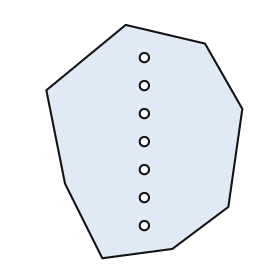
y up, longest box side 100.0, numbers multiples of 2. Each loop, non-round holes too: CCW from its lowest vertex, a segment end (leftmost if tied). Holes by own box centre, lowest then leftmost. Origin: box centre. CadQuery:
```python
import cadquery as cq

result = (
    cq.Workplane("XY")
    .moveTo(-18.0, -50.0)
    .lineTo(12.0, -46.0)
    .lineTo(36.0, -28.0)
    .lineTo(42.0, 14.0)
    .lineTo(26.0, 42.0)
    .lineTo(-8.0, 50.0)
    .lineTo(-42.0, 22.0)
    .lineTo(-34.0, -18.0)
    .close()
    .moveTo(0.0, -36.0)
    .circle(2.0)
    .moveTo(0.0, -24.0)
    .circle(2.0)
    .moveTo(0.0, -12.0)
    .circle(2.0)
    .moveTo(0.0, 0.0)
    .circle(2.0)
    .moveTo(0.0, 12.0)
    .circle(2.0)
    .moveTo(0.0, 24.0)
    .circle(2.0)
    .moveTo(0.0, 36.0)
    .circle(2.0)
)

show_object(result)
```